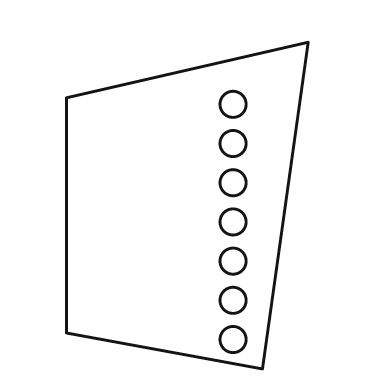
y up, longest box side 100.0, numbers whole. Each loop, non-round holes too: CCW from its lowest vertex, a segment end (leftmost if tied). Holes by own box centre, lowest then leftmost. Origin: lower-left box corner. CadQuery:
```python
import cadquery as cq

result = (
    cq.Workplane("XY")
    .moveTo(60.0, 0.0)
    .lineTo(74.0, 100.0)
    .lineTo(0.0, 83.0)
    .lineTo(0.0, 11.0)
    .close()
    .moveTo(51.0, 9.0)
    .circle(4.0)
    .moveTo(51.0, 21.0)
    .circle(4.0)
    .moveTo(51.0, 33.0)
    .circle(4.0)
    .moveTo(51.0, 45.0)
    .circle(4.0)
    .moveTo(51.0, 57.0)
    .circle(4.0)
    .moveTo(51.0, 69.0)
    .circle(4.0)
    .moveTo(51.0, 81.0)
    .circle(4.0)
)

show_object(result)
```